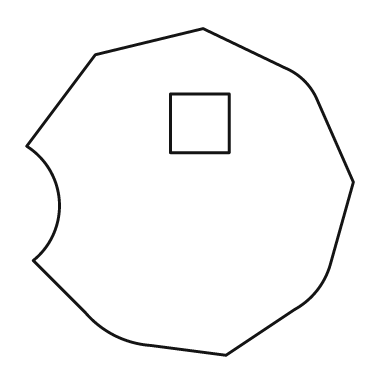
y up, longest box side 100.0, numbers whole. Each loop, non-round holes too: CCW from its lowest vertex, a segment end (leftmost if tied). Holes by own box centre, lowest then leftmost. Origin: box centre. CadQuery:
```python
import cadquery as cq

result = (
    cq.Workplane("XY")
    .moveTo(11.0, -50.0)
    .lineTo(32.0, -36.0)
    .threePointArc((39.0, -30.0), (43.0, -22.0))
    .lineTo(50.0, 3.0)
    .lineTo(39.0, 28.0)
    .threePointArc((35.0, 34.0), (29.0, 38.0))
    .lineTo(4.0, 50.0)
    .lineTo(-29.0, 42.0)
    .lineTo(-50.0, 14.0)
    .threePointArc((-40.0, -3.0), (-48.0, -21.0))
    .lineTo(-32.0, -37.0)
    .threePointArc((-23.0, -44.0), (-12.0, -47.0))
    .close()
    .moveTo(-6.0, 12.0)
    .lineTo(12.0, 12.0)
    .lineTo(12.0, 30.0)
    .lineTo(-6.0, 30.0)
    .close()
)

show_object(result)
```